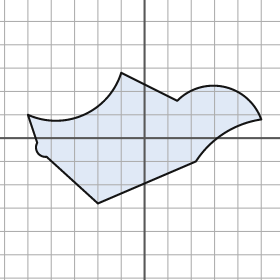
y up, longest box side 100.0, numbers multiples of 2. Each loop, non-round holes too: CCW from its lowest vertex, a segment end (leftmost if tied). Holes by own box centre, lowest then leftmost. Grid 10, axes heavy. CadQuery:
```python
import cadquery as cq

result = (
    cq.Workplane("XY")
    .moveTo(-20.0, -28.0)
    .lineTo(22.0, -10.0)
    .threePointArc((34.0, 2.0), (50.0, 8.0))
    .threePointArc((34.0, 22.0), (14.0, 16.0))
    .lineTo(-10.0, 28.0)
    .threePointArc((-26.0, 10.0), (-50.0, 10.0))
    .lineTo(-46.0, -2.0)
    .threePointArc((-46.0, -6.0), (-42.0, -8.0))
    .close()
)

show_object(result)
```